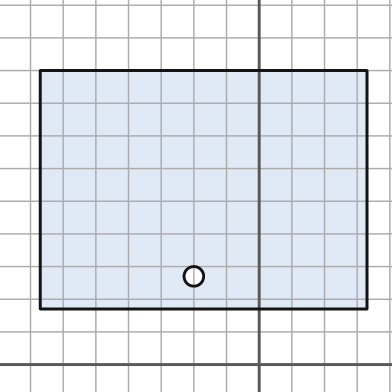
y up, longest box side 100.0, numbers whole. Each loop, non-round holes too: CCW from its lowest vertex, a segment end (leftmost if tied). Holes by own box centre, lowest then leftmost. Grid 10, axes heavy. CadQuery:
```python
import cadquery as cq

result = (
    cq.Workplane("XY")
    .moveTo(-67.0, 17.0)
    .lineTo(33.0, 17.0)
    .lineTo(33.0, 90.0)
    .lineTo(-67.0, 90.0)
    .close()
    .moveTo(-20.0, 27.0)
    .circle(3.0)
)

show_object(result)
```